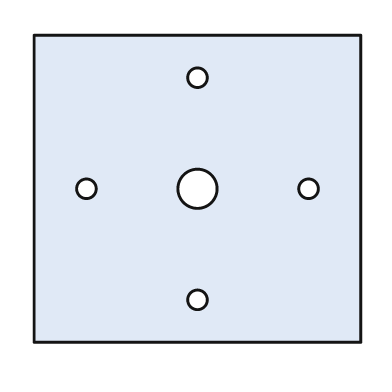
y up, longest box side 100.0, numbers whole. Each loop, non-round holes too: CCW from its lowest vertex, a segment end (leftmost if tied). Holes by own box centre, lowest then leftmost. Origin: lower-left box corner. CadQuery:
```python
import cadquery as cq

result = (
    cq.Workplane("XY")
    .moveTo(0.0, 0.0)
    .lineTo(100.0, 0.0)
    .lineTo(100.0, 94.0)
    .lineTo(0.0, 94.0)
    .close()
    .moveTo(50.0, 13.0)
    .circle(3.0)
    .moveTo(16.0, 47.0)
    .circle(3.0)
    .moveTo(50.0, 47.0)
    .circle(6.0)
    .moveTo(84.0, 47.0)
    .circle(3.0)
    .moveTo(50.0, 81.0)
    .circle(3.0)
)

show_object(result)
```